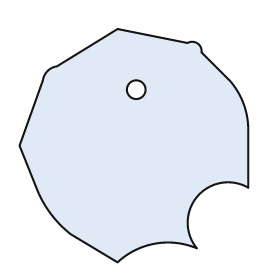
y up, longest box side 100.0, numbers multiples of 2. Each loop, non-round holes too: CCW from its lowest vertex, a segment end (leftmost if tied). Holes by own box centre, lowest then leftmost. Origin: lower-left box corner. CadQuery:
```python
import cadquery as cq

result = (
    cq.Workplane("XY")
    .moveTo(42.0, 0.0)
    .threePointArc((58.0, 8.0), (76.0, 6.0))
    .threePointArc((76.0, 28.0), (98.0, 32.0))
    .lineTo(98.0, 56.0)
    .threePointArc((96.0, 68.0), (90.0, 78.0))
    .lineTo(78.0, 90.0)
    .threePointArc((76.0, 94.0), (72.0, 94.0))
    .lineTo(42.0, 100.0)
    .lineTo(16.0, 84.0)
    .threePointArc((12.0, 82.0), (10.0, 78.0))
    .lineTo(0.0, 50.0)
    .lineTo(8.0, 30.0)
    .threePointArc((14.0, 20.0), (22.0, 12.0))
    .close()
    .moveTo(50.0, 74.0)
    .circle(4.0)
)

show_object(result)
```